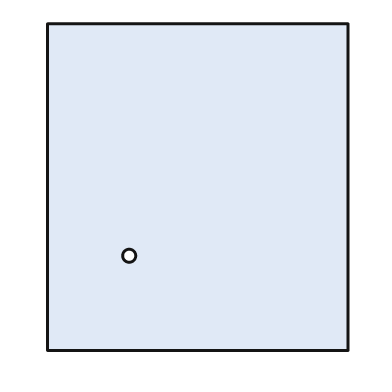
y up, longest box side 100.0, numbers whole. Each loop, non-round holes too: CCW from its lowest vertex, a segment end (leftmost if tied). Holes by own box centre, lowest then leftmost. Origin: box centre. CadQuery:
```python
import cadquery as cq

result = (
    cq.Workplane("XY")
    .moveTo(-46.0, -50.0)
    .lineTo(46.0, -50.0)
    .lineTo(46.0, 50.0)
    .lineTo(-46.0, 50.0)
    .close()
    .moveTo(-21.0, -21.0)
    .circle(2.0)
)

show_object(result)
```